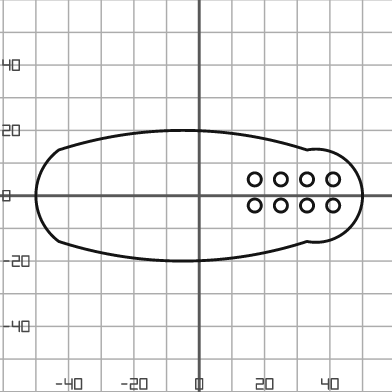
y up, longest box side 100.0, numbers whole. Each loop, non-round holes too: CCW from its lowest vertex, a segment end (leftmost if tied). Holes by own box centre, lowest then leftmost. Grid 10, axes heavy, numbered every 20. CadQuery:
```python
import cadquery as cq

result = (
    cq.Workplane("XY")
    .moveTo(-43.0, -14.0)
    .threePointArc((-5.0, -20.0), (33.0, -14.0))
    .threePointArc((50.0, 0.0), (33.0, 14.0))
    .threePointArc((-5.0, 20.0), (-43.0, 14.0))
    .threePointArc((-50.0, 0.0), (-43.0, -14.0))
    .close()
    .moveTo(17.0, -3.0)
    .circle(2.0)
    .moveTo(25.0, -3.0)
    .circle(2.0)
    .moveTo(33.0, -3.0)
    .circle(2.0)
    .moveTo(41.0, -3.0)
    .circle(2.0)
    .moveTo(17.0, 5.0)
    .circle(2.0)
    .moveTo(25.0, 5.0)
    .circle(2.0)
    .moveTo(33.0, 5.0)
    .circle(2.0)
    .moveTo(41.0, 5.0)
    .circle(2.0)
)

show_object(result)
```